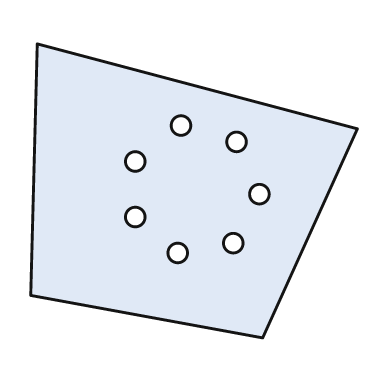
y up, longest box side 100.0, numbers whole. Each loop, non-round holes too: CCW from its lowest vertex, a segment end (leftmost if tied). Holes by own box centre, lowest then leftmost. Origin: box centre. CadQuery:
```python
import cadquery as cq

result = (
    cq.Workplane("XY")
    .moveTo(21.0, -45.0)
    .lineTo(50.0, 19.0)
    .lineTo(-48.0, 45.0)
    .lineTo(-50.0, -32.0)
    .close()
    .moveTo(-5.0, -19.0)
    .circle(3.0)
    .moveTo(12.0, -16.0)
    .circle(3.0)
    .moveTo(-18.0, -8.0)
    .circle(3.0)
    .moveTo(20.0, -1.0)
    .circle(3.0)
    .moveTo(-18.0, 9.0)
    .circle(3.0)
    .moveTo(13.0, 15.0)
    .circle(3.0)
    .moveTo(-4.0, 20.0)
    .circle(3.0)
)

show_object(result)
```